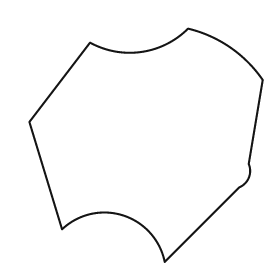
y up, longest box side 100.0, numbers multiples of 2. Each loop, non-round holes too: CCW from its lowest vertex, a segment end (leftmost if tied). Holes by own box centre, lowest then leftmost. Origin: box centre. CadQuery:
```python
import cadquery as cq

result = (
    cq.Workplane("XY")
    .moveTo(8.0, -50.0)
    .lineTo(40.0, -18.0)
    .threePointArc((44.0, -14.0), (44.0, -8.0))
    .lineTo(50.0, 28.0)
    .threePointArc((36.0, 42.0), (18.0, 50.0))
    .threePointArc((-2.0, 40.0), (-24.0, 44.0))
    .lineTo(-50.0, 10.0)
    .lineTo(-36.0, -36.0)
    .threePointArc((-10.0, -30.0), (8.0, -50.0))
    .close()
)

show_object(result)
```